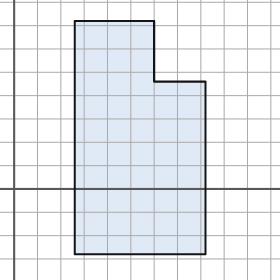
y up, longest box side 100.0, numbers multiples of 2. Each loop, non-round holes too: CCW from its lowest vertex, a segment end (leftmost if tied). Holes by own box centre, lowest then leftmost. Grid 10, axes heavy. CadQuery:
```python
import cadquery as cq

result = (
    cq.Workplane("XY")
    .moveTo(26.0, -28.0)
    .lineTo(82.0, -28.0)
    .lineTo(82.0, 46.0)
    .lineTo(60.0, 46.0)
    .lineTo(60.0, 72.0)
    .lineTo(26.0, 72.0)
    .close()
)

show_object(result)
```